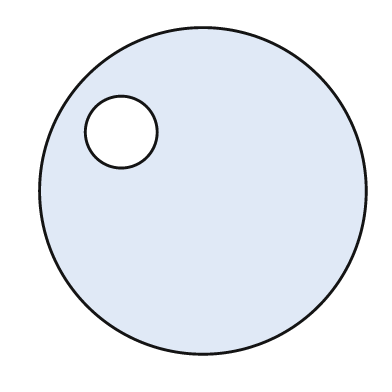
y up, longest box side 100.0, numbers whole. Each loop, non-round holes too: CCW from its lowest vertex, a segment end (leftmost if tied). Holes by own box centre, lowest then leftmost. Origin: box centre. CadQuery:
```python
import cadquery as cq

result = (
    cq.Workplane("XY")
    .moveTo(0.0, 0.0)
    .circle(50.0)
    .moveTo(-25.0, 18.0)
    .circle(11.0)
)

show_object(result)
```